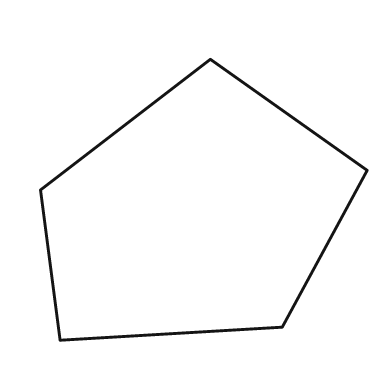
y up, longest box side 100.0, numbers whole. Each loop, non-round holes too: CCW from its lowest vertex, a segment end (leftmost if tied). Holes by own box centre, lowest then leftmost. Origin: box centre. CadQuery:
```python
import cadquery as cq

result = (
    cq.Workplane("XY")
    .moveTo(-44.0, -43.0)
    .lineTo(24.0, -39.0)
    .lineTo(50.0, 9.0)
    .lineTo(2.0, 43.0)
    .lineTo(-50.0, 3.0)
    .close()
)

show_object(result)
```